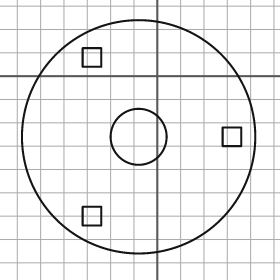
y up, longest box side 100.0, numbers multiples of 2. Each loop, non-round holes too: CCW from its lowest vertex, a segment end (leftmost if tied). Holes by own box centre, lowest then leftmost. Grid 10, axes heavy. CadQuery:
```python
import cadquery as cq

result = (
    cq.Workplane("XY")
    .moveTo(-8.0, -26.0)
    .circle(50.0)
    .moveTo(-32.0, -64.0)
    .lineTo(-24.0, -64.0)
    .lineTo(-24.0, -56.0)
    .lineTo(-32.0, -56.0)
    .close()
    .moveTo(-8.0, -26.0)
    .circle(12.0)
    .moveTo(28.0, -30.0)
    .lineTo(36.0, -30.0)
    .lineTo(36.0, -22.0)
    .lineTo(28.0, -22.0)
    .close()
    .moveTo(-32.0, 4.0)
    .lineTo(-24.0, 4.0)
    .lineTo(-24.0, 12.0)
    .lineTo(-32.0, 12.0)
    .close()
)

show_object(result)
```